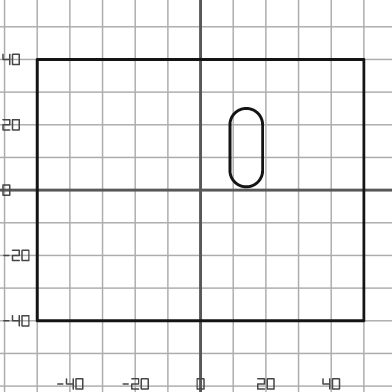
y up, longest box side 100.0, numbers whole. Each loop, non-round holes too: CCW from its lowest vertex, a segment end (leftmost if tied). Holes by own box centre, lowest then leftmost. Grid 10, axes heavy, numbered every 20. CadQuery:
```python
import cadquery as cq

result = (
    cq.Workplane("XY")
    .moveTo(-50.0, -40.0)
    .lineTo(50.0, -40.0)
    .lineTo(50.0, 40.0)
    .lineTo(-50.0, 40.0)
    .close()
    .moveTo(9.0, 6.0)
    .threePointArc((14.0, 1.0), (19.0, 6.0))
    .lineTo(19.0, 20.0)
    .threePointArc((14.0, 25.0), (9.0, 20.0))
    .close()
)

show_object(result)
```